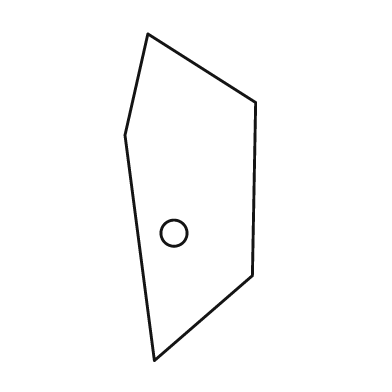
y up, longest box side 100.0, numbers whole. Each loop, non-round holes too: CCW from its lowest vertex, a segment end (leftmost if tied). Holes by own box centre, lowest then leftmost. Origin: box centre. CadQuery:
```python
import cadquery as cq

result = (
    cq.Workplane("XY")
    .moveTo(-11.0, -50.0)
    .lineTo(19.0, -24.0)
    .lineTo(20.0, 29.0)
    .lineTo(-13.0, 50.0)
    .lineTo(-20.0, 19.0)
    .close()
    .moveTo(-5.0, -11.0)
    .circle(4.0)
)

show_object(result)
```